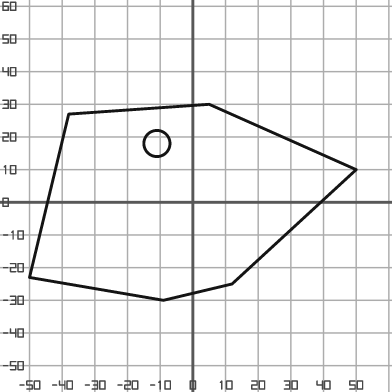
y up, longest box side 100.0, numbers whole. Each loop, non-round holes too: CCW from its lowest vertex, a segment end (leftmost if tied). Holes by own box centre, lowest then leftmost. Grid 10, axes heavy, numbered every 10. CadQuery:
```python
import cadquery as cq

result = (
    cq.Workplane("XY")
    .moveTo(-9.0, -30.0)
    .lineTo(12.0, -25.0)
    .lineTo(50.0, 10.0)
    .lineTo(5.0, 30.0)
    .lineTo(-38.0, 27.0)
    .lineTo(-50.0, -23.0)
    .close()
    .moveTo(-11.0, 18.0)
    .circle(4.0)
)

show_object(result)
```